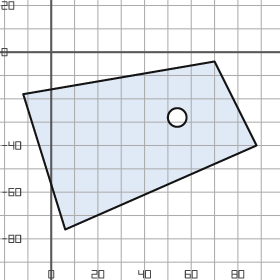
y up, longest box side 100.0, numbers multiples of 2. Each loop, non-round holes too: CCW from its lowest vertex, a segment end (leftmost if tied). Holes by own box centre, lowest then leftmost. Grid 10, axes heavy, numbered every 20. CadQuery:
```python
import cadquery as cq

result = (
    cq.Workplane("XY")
    .moveTo(6.0, -76.0)
    .lineTo(88.0, -40.0)
    .lineTo(70.0, -4.0)
    .lineTo(-12.0, -18.0)
    .close()
    .moveTo(54.0, -28.0)
    .circle(4.0)
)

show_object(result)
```